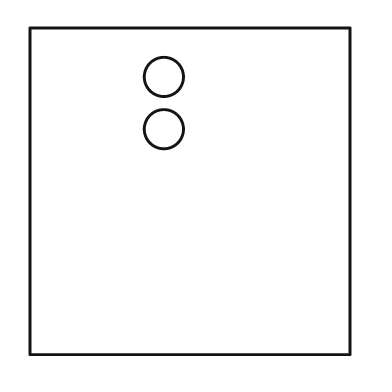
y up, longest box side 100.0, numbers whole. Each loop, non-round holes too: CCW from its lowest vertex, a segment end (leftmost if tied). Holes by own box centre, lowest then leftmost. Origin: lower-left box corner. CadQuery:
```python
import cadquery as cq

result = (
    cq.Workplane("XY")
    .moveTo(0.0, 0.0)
    .lineTo(98.0, 0.0)
    .lineTo(98.0, 100.0)
    .lineTo(0.0, 100.0)
    .close()
    .moveTo(41.0, 69.0)
    .circle(6.0)
    .moveTo(41.0, 85.0)
    .circle(6.0)
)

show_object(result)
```